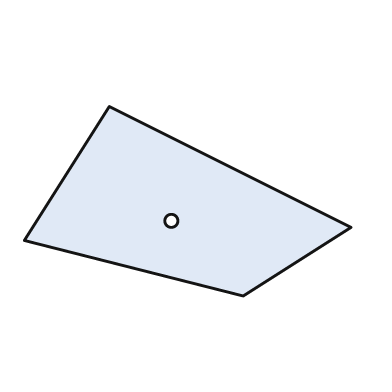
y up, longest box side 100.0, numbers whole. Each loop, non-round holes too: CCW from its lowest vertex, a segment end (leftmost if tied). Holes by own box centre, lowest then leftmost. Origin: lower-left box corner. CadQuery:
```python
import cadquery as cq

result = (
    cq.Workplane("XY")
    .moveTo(67.0, 0.0)
    .lineTo(100.0, 21.0)
    .lineTo(26.0, 58.0)
    .lineTo(0.0, 17.0)
    .close()
    .moveTo(45.0, 23.0)
    .circle(2.0)
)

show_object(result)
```